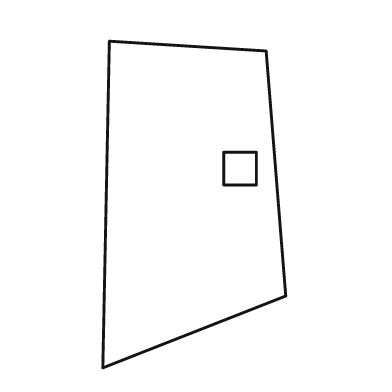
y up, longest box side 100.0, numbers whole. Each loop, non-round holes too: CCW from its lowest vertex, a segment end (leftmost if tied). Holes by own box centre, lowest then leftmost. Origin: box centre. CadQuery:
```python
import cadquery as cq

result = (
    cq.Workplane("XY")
    .moveTo(-28.0, -50.0)
    .lineTo(28.0, -28.0)
    .lineTo(22.0, 47.0)
    .lineTo(-26.0, 50.0)
    .close()
    .moveTo(9.0, 6.0)
    .lineTo(19.0, 6.0)
    .lineTo(19.0, 16.0)
    .lineTo(9.0, 16.0)
    .close()
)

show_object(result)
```